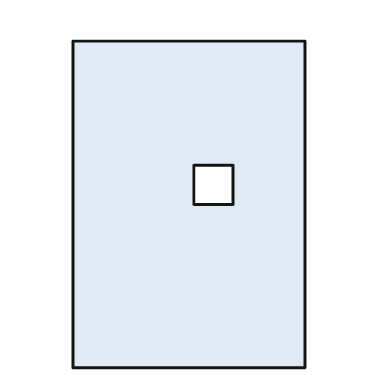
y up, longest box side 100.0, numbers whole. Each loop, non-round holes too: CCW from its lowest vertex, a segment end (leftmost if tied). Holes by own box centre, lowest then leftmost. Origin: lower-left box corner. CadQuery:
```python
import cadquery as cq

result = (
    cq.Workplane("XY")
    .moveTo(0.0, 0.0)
    .lineTo(71.0, 0.0)
    .lineTo(71.0, 100.0)
    .lineTo(0.0, 100.0)
    .close()
    .moveTo(37.0, 50.0)
    .lineTo(49.0, 50.0)
    .lineTo(49.0, 62.0)
    .lineTo(37.0, 62.0)
    .close()
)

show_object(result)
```